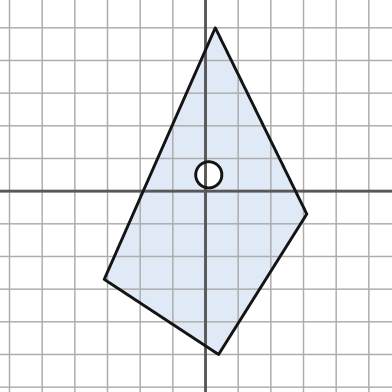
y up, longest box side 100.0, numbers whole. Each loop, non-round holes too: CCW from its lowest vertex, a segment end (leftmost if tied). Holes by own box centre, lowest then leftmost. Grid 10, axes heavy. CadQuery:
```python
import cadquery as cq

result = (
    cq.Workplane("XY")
    .moveTo(4.0, -50.0)
    .lineTo(31.0, -7.0)
    .lineTo(3.0, 50.0)
    .lineTo(-31.0, -27.0)
    .close()
    .moveTo(1.0, 5.0)
    .circle(4.0)
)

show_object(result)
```